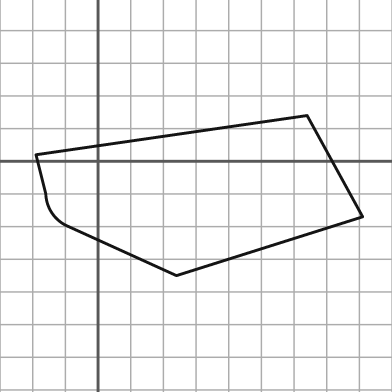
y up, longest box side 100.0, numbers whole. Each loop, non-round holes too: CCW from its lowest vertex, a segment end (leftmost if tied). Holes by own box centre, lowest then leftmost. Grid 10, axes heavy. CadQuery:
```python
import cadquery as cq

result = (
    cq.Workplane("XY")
    .moveTo(24.0, -35.0)
    .lineTo(81.0, -17.0)
    .lineTo(64.0, 14.0)
    .lineTo(-19.0, 2.0)
    .lineTo(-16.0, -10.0)
    .threePointArc((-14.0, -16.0), (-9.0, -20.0))
    .close()
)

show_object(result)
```